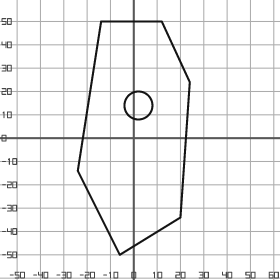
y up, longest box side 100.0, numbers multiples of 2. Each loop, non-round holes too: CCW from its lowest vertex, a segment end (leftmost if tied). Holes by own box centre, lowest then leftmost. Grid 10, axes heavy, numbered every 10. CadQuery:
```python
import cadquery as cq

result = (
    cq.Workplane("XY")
    .moveTo(-6.0, -50.0)
    .lineTo(20.0, -34.0)
    .lineTo(24.0, 24.0)
    .lineTo(12.0, 50.0)
    .lineTo(-14.0, 50.0)
    .lineTo(-24.0, -14.0)
    .close()
    .moveTo(2.0, 14.0)
    .circle(6.0)
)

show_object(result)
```